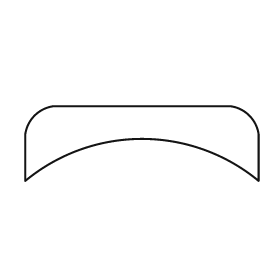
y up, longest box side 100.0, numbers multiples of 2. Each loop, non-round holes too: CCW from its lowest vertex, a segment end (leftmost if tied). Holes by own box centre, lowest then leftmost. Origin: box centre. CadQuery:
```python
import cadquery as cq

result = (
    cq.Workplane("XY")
    .moveTo(-50.0, -16.0)
    .threePointArc((0.0, 2.0), (50.0, -16.0))
    .lineTo(50.0, 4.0)
    .threePointArc((46.0, 12.0), (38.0, 16.0))
    .lineTo(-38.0, 16.0)
    .threePointArc((-46.0, 12.0), (-50.0, 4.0))
    .close()
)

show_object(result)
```